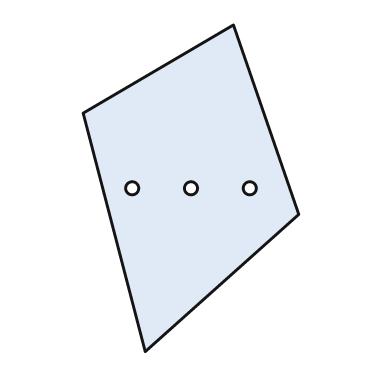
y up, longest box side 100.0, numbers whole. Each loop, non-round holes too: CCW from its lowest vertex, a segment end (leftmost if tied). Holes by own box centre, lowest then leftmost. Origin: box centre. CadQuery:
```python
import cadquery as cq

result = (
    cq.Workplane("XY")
    .moveTo(-14.0, -50.0)
    .lineTo(33.0, -8.0)
    .lineTo(13.0, 50.0)
    .lineTo(-33.0, 23.0)
    .close()
    .moveTo(-18.0, 0.0)
    .circle(2.0)
    .moveTo(0.0, 0.0)
    .circle(2.0)
    .moveTo(18.0, 0.0)
    .circle(2.0)
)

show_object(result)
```